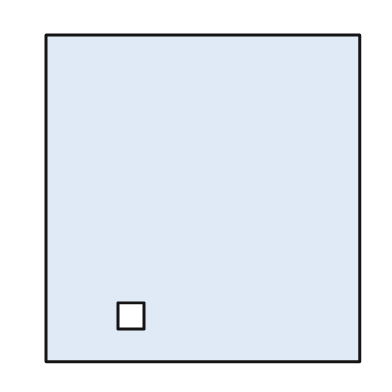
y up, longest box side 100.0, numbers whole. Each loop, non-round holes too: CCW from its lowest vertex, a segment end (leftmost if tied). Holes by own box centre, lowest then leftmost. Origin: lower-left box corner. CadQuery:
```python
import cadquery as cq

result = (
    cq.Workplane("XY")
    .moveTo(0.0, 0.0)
    .lineTo(96.0, 0.0)
    .lineTo(96.0, 100.0)
    .lineTo(0.0, 100.0)
    .close()
    .moveTo(22.0, 10.0)
    .lineTo(30.0, 10.0)
    .lineTo(30.0, 18.0)
    .lineTo(22.0, 18.0)
    .close()
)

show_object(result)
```